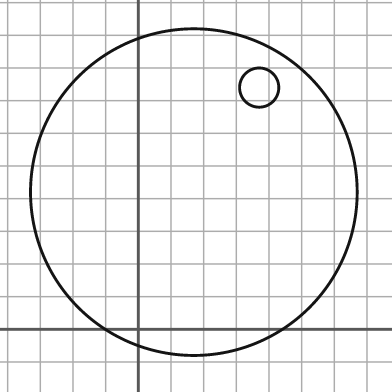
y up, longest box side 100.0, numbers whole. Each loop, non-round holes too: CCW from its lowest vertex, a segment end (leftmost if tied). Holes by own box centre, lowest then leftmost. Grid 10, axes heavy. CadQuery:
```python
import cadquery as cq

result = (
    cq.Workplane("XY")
    .moveTo(17.0, 42.0)
    .circle(50.0)
    .moveTo(37.0, 74.0)
    .circle(6.0)
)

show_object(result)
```